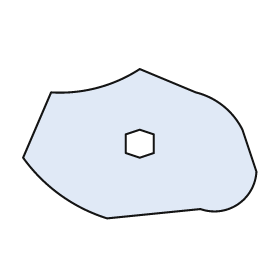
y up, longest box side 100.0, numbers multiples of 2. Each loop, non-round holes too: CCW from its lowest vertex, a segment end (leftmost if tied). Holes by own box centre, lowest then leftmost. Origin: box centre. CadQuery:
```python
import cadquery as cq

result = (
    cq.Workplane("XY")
    .moveTo(-14.0, -32.0)
    .lineTo(26.0, -28.0)
    .threePointArc((42.0, -26.0), (50.0, -12.0))
    .lineTo(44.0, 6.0)
    .threePointArc((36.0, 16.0), (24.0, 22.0))
    .lineTo(0.0, 32.0)
    .threePointArc((-18.0, 24.0), (-38.0, 22.0))
    .lineTo(-50.0, -6.0)
    .threePointArc((-34.0, -22.0), (-14.0, -32.0))
    .close()
    .moveTo(0.0, -6.0)
    .lineTo(6.0, -4.0)
    .lineTo(6.0, 4.0)
    .lineTo(0.0, 6.0)
    .lineTo(-6.0, 4.0)
    .lineTo(-6.0, -4.0)
    .close()
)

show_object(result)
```